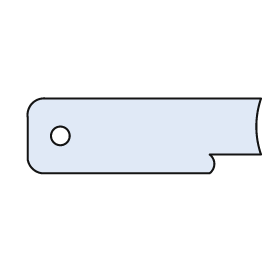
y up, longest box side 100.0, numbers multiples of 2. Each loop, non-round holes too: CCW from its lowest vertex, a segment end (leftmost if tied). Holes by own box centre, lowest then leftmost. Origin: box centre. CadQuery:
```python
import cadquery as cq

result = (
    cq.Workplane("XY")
    .moveTo(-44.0, -16.0)
    .lineTo(28.0, -16.0)
    .threePointArc((30.0, -12.0), (28.0, -8.0))
    .lineTo(50.0, -8.0)
    .threePointArc((48.0, 4.0), (50.0, 16.0))
    .lineTo(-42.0, 16.0)
    .threePointArc((-48.0, 14.0), (-50.0, 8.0))
    .lineTo(-50.0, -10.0)
    .threePointArc((-48.0, -14.0), (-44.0, -16.0))
    .close()
    .moveTo(-36.0, 0.0)
    .circle(4.0)
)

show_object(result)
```